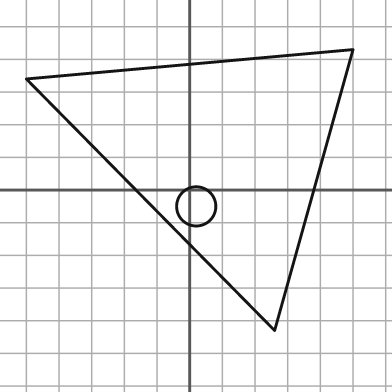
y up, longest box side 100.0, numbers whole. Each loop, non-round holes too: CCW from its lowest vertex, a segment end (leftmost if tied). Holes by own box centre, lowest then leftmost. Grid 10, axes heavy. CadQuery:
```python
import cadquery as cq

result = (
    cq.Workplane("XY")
    .moveTo(26.0, -43.0)
    .lineTo(50.0, 43.0)
    .lineTo(-50.0, 34.0)
    .close()
    .moveTo(2.0, -5.0)
    .circle(6.0)
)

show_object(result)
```